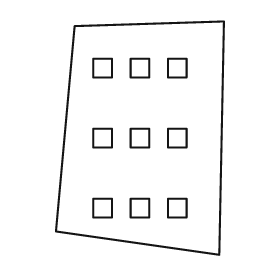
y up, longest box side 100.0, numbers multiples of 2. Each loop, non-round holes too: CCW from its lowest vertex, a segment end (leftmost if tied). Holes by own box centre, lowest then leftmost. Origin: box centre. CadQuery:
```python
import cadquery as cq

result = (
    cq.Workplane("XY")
    .moveTo(34.0, -50.0)
    .lineTo(36.0, 50.0)
    .lineTo(-28.0, 48.0)
    .lineTo(-36.0, -40.0)
    .close()
    .moveTo(-20.0, -34.0)
    .lineTo(-12.0, -34.0)
    .lineTo(-12.0, -26.0)
    .lineTo(-20.0, -26.0)
    .close()
    .moveTo(-4.0, -34.0)
    .lineTo(4.0, -34.0)
    .lineTo(4.0, -26.0)
    .lineTo(-4.0, -26.0)
    .close()
    .moveTo(12.0, -34.0)
    .lineTo(20.0, -34.0)
    .lineTo(20.0, -26.0)
    .lineTo(12.0, -26.0)
    .close()
    .moveTo(-20.0, -4.0)
    .lineTo(-12.0, -4.0)
    .lineTo(-12.0, 4.0)
    .lineTo(-20.0, 4.0)
    .close()
    .moveTo(-4.0, -4.0)
    .lineTo(4.0, -4.0)
    .lineTo(4.0, 4.0)
    .lineTo(-4.0, 4.0)
    .close()
    .moveTo(12.0, -4.0)
    .lineTo(20.0, -4.0)
    .lineTo(20.0, 4.0)
    .lineTo(12.0, 4.0)
    .close()
    .moveTo(-20.0, 26.0)
    .lineTo(-12.0, 26.0)
    .lineTo(-12.0, 34.0)
    .lineTo(-20.0, 34.0)
    .close()
    .moveTo(-4.0, 26.0)
    .lineTo(4.0, 26.0)
    .lineTo(4.0, 34.0)
    .lineTo(-4.0, 34.0)
    .close()
    .moveTo(12.0, 26.0)
    .lineTo(20.0, 26.0)
    .lineTo(20.0, 34.0)
    .lineTo(12.0, 34.0)
    .close()
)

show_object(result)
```